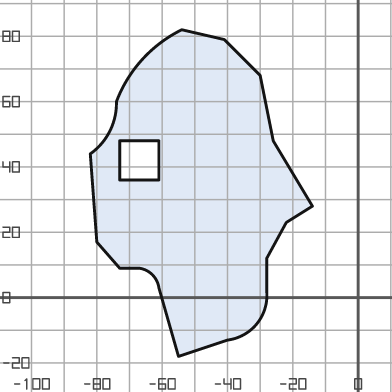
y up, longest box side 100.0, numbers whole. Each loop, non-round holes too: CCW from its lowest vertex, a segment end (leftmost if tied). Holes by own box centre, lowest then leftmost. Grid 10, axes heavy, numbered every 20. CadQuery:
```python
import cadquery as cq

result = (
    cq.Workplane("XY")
    .moveTo(-55.0, -18.0)
    .lineTo(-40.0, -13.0)
    .threePointArc((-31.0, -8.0), (-28.0, 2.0))
    .lineTo(-28.0, 12.0)
    .lineTo(-22.0, 23.0)
    .lineTo(-14.0, 28.0)
    .lineTo(-26.0, 48.0)
    .lineTo(-30.0, 68.0)
    .lineTo(-41.0, 79.0)
    .lineTo(-54.0, 82.0)
    .threePointArc((-66.0, 73.0), (-74.0, 60.0))
    .threePointArc((-76.0, 51.0), (-82.0, 44.0))
    .lineTo(-80.0, 17.0)
    .lineTo(-73.0, 9.0)
    .lineTo(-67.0, 9.0)
    .threePointArc((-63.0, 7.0), (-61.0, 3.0))
    .close()
    .moveTo(-73.0, 36.0)
    .lineTo(-61.0, 36.0)
    .lineTo(-61.0, 48.0)
    .lineTo(-73.0, 48.0)
    .close()
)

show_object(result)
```